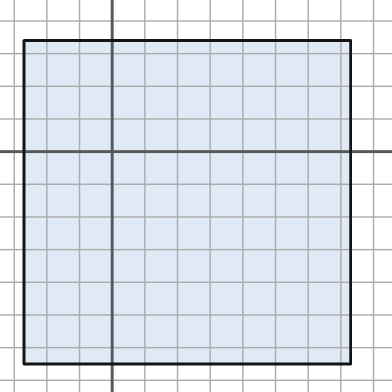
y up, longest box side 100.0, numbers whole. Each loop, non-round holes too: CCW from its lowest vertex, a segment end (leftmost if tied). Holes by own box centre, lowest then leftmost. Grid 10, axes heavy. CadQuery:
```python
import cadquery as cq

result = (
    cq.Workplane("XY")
    .moveTo(-27.0, -65.0)
    .lineTo(73.0, -65.0)
    .lineTo(73.0, 34.0)
    .lineTo(-27.0, 34.0)
    .close()
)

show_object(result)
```